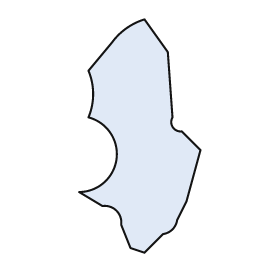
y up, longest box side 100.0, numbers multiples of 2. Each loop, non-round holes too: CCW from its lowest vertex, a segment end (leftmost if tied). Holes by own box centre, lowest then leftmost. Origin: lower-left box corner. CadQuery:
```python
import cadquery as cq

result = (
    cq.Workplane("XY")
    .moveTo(28.0, 0.0)
    .lineTo(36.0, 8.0)
    .threePointArc((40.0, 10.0), (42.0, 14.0))
    .lineTo(46.0, 22.0)
    .lineTo(52.0, 44.0)
    .lineTo(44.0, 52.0)
    .threePointArc((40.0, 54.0), (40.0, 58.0))
    .lineTo(38.0, 86.0)
    .lineTo(28.0, 100.0)
    .threePointArc((20.0, 96.0), (14.0, 90.0))
    .lineTo(4.0, 78.0)
    .threePointArc((6.0, 68.0), (4.0, 58.0))
    .threePointArc((16.0, 40.0), (0.0, 26.0))
    .lineTo(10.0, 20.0)
    .threePointArc((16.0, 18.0), (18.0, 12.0))
    .lineTo(22.0, 2.0)
    .close()
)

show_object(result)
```